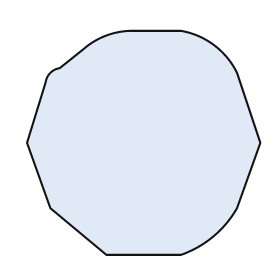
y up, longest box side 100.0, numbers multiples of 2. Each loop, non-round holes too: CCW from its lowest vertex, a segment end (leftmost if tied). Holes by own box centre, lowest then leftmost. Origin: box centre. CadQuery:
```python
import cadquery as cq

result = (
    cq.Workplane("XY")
    .moveTo(-16.0, -48.0)
    .lineTo(16.0, -48.0)
    .threePointArc((30.0, -40.0), (40.0, -28.0))
    .lineTo(50.0, 0.0)
    .lineTo(40.0, 30.0)
    .threePointArc((30.0, 42.0), (16.0, 48.0))
    .lineTo(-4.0, 48.0)
    .threePointArc((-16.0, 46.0), (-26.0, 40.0))
    .lineTo(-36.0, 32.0)
    .threePointArc((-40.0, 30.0), (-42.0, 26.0))
    .lineTo(-50.0, 0.0)
    .lineTo(-40.0, -28.0)
    .close()
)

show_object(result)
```